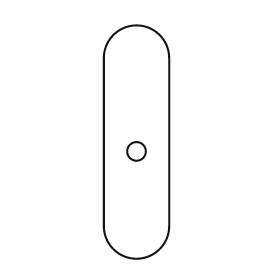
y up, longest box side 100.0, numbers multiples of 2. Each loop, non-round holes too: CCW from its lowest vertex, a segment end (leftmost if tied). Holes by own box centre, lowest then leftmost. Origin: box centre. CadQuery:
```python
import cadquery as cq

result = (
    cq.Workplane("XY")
    .moveTo(-14.0, -36.0)
    .threePointArc((0.0, -50.0), (14.0, -36.0))
    .lineTo(14.0, 36.0)
    .threePointArc((0.0, 50.0), (-14.0, 36.0))
    .close()
    .moveTo(0.0, -4.0)
    .circle(4.0)
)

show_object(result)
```